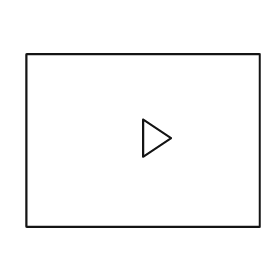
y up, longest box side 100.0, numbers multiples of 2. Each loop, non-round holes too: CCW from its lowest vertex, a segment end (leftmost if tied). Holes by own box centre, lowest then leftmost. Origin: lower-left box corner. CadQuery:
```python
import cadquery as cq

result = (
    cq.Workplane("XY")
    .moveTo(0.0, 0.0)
    .lineTo(100.0, 0.0)
    .lineTo(100.0, 74.0)
    .lineTo(0.0, 74.0)
    .close()
    .moveTo(50.0, 30.0)
    .lineTo(62.0, 38.0)
    .lineTo(50.0, 46.0)
    .close()
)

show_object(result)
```